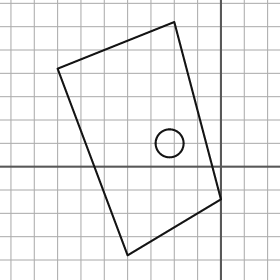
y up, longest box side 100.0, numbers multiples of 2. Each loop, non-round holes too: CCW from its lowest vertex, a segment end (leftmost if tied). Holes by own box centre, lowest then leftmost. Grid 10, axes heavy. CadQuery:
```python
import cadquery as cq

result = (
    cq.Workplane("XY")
    .moveTo(-40.0, -38.0)
    .lineTo(0.0, -14.0)
    .lineTo(-20.0, 62.0)
    .lineTo(-70.0, 42.0)
    .close()
    .moveTo(-22.0, 10.0)
    .circle(6.0)
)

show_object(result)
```